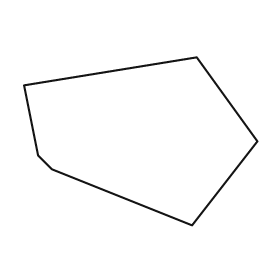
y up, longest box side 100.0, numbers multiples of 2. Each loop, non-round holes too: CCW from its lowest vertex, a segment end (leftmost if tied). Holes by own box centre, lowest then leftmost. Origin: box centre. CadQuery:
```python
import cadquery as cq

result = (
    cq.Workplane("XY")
    .moveTo(22.0, -36.0)
    .lineTo(50.0, 0.0)
    .lineTo(24.0, 36.0)
    .lineTo(-50.0, 24.0)
    .lineTo(-44.0, -6.0)
    .lineTo(-38.0, -12.0)
    .close()
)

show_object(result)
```